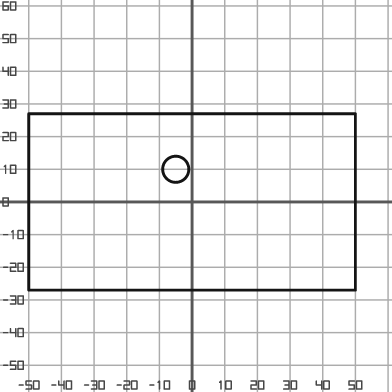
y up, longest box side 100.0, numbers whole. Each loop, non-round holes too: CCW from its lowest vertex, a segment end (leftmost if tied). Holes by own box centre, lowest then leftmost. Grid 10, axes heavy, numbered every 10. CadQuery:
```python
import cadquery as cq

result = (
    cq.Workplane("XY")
    .moveTo(-50.0, -27.0)
    .lineTo(50.0, -27.0)
    .lineTo(50.0, 27.0)
    .lineTo(-50.0, 27.0)
    .close()
    .moveTo(-5.0, 10.0)
    .circle(4.0)
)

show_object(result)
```